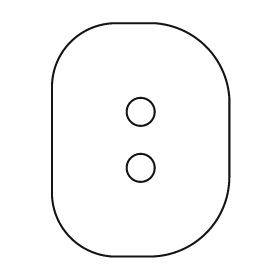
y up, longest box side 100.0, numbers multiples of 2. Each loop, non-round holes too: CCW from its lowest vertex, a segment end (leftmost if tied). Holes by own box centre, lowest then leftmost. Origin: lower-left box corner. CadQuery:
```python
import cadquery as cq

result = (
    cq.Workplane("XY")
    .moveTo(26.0, 0.0)
    .lineTo(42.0, 0.0)
    .threePointArc((66.0, 10.0), (76.0, 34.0))
    .lineTo(76.0, 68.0)
    .threePointArc((66.0, 90.0), (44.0, 100.0))
    .lineTo(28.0, 100.0)
    .threePointArc((8.0, 92.0), (0.0, 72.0))
    .lineTo(0.0, 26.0)
    .threePointArc((8.0, 8.0), (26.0, 0.0))
    .close()
    .moveTo(38.0, 38.0)
    .circle(6.0)
    .moveTo(38.0, 62.0)
    .circle(6.0)
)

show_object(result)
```